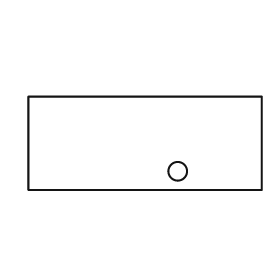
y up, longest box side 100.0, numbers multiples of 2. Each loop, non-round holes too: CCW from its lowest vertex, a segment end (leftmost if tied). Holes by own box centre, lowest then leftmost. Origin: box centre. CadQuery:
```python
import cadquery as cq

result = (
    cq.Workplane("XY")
    .moveTo(-50.0, -20.0)
    .lineTo(50.0, -20.0)
    .lineTo(50.0, 20.0)
    .lineTo(-50.0, 20.0)
    .close()
    .moveTo(14.0, -12.0)
    .circle(4.0)
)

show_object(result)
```